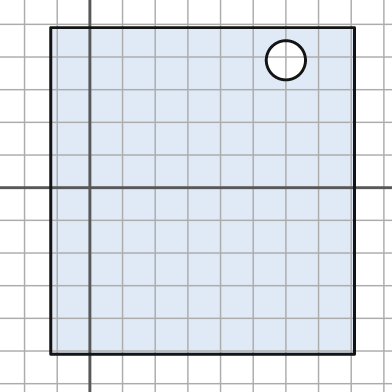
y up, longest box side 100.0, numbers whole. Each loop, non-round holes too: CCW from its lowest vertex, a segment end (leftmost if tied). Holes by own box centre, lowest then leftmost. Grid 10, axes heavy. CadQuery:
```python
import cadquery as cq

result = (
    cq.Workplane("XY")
    .moveTo(-12.0, -51.0)
    .lineTo(81.0, -51.0)
    .lineTo(81.0, 49.0)
    .lineTo(-12.0, 49.0)
    .close()
    .moveTo(60.0, 39.0)
    .circle(6.0)
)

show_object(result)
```